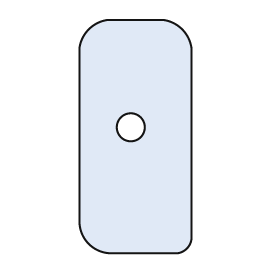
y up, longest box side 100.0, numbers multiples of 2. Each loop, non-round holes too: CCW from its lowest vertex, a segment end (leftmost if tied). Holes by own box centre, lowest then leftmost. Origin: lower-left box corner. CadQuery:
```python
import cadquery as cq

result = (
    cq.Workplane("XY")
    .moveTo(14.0, 0.0)
    .lineTo(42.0, 0.0)
    .threePointArc((46.0, 2.0), (48.0, 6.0))
    .lineTo(48.0, 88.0)
    .threePointArc((44.0, 96.0), (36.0, 100.0))
    .lineTo(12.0, 100.0)
    .threePointArc((4.0, 96.0), (0.0, 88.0))
    .lineTo(0.0, 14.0)
    .threePointArc((4.0, 4.0), (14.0, 0.0))
    .close()
    .moveTo(22.0, 54.0)
    .circle(6.0)
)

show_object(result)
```